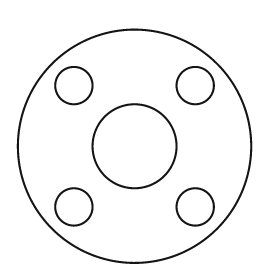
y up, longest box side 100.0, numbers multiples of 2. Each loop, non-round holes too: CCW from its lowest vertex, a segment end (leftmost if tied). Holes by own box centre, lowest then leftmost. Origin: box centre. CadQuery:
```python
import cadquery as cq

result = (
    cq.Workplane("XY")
    .moveTo(0.0, 0.0)
    .circle(50.0)
    .moveTo(-26.0, -26.0)
    .circle(8.0)
    .moveTo(26.0, -26.0)
    .circle(8.0)
    .moveTo(0.0, 0.0)
    .circle(18.0)
    .moveTo(-26.0, 26.0)
    .circle(8.0)
    .moveTo(26.0, 26.0)
    .circle(8.0)
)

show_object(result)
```